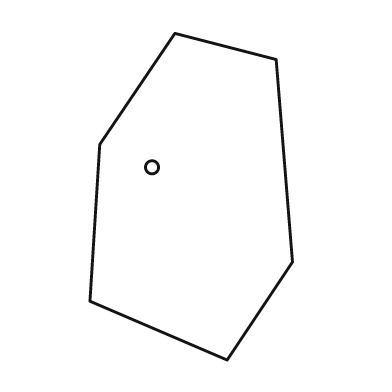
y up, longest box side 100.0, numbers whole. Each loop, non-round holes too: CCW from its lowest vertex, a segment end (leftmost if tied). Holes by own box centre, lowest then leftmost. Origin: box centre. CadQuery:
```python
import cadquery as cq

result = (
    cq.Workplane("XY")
    .moveTo(11.0, -50.0)
    .lineTo(31.0, -20.0)
    .lineTo(26.0, 42.0)
    .lineTo(-5.0, 50.0)
    .lineTo(-28.0, 16.0)
    .lineTo(-31.0, -32.0)
    .close()
    .moveTo(-12.0, 9.0)
    .circle(2.0)
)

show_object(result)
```